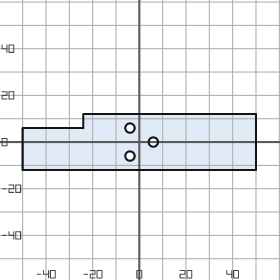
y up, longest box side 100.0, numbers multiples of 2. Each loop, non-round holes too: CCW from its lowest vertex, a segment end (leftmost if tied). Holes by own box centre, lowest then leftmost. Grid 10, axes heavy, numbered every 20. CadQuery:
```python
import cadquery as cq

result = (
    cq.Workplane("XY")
    .moveTo(-50.0, -12.0)
    .lineTo(50.0, -12.0)
    .lineTo(50.0, 12.0)
    .lineTo(-24.0, 12.0)
    .lineTo(-24.0, 6.0)
    .lineTo(-50.0, 6.0)
    .close()
    .moveTo(-4.0, -6.0)
    .circle(2.0)
    .moveTo(6.0, 0.0)
    .circle(2.0)
    .moveTo(-4.0, 6.0)
    .circle(2.0)
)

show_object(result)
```